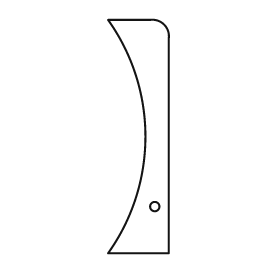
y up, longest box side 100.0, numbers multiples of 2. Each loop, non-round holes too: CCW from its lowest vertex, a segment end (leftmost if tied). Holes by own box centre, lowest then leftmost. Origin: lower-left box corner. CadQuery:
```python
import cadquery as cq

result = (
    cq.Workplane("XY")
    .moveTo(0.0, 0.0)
    .lineTo(26.0, 0.0)
    .lineTo(26.0, 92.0)
    .threePointArc((24.0, 98.0), (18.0, 100.0))
    .lineTo(0.0, 100.0)
    .threePointArc((16.0, 50.0), (0.0, 0.0))
    .close()
    .moveTo(20.0, 20.0)
    .circle(2.0)
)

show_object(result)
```